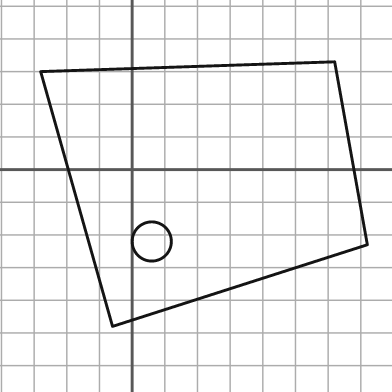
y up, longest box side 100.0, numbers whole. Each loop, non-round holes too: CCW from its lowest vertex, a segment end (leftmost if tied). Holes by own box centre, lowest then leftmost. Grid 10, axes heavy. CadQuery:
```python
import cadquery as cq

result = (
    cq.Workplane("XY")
    .moveTo(-6.0, -48.0)
    .lineTo(72.0, -23.0)
    .lineTo(62.0, 33.0)
    .lineTo(-28.0, 30.0)
    .close()
    .moveTo(6.0, -22.0)
    .circle(6.0)
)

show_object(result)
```